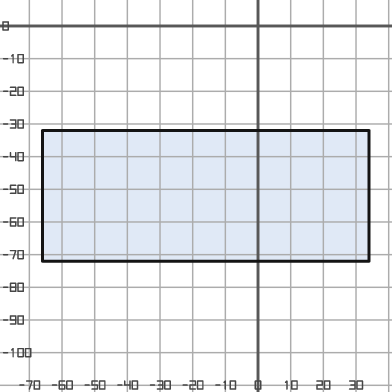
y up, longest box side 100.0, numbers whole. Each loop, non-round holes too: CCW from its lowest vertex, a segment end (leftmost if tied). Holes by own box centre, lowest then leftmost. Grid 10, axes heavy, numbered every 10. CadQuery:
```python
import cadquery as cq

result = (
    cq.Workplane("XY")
    .moveTo(-66.0, -72.0)
    .lineTo(34.0, -72.0)
    .lineTo(34.0, -32.0)
    .lineTo(-66.0, -32.0)
    .close()
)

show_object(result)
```